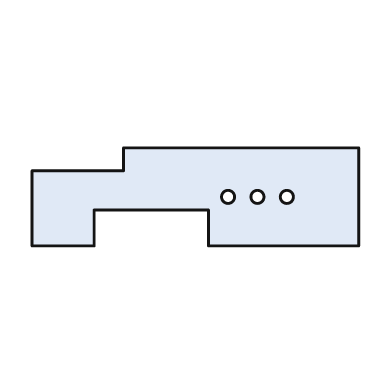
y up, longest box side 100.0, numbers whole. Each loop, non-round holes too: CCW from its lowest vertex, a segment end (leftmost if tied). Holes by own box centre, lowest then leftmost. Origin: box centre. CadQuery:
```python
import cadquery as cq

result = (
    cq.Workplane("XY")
    .moveTo(-50.0, -15.0)
    .lineTo(-31.0, -15.0)
    .lineTo(-31.0, -4.0)
    .lineTo(4.0, -4.0)
    .lineTo(4.0, -15.0)
    .lineTo(50.0, -15.0)
    .lineTo(50.0, 15.0)
    .lineTo(-22.0, 15.0)
    .lineTo(-22.0, 8.0)
    .lineTo(-50.0, 8.0)
    .close()
    .moveTo(10.0, 0.0)
    .circle(2.0)
    .moveTo(19.0, 0.0)
    .circle(2.0)
    .moveTo(28.0, 0.0)
    .circle(2.0)
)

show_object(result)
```